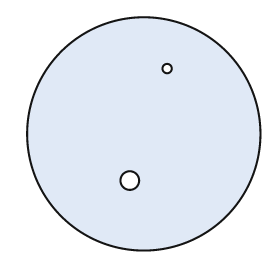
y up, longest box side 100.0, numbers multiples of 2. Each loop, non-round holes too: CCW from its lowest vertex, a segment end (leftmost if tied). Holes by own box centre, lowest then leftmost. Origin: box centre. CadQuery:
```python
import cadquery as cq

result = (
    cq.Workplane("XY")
    .moveTo(0.0, 0.0)
    .circle(50.0)
    .moveTo(-6.0, -20.0)
    .circle(4.0)
    .moveTo(10.0, 28.0)
    .circle(2.0)
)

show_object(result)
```